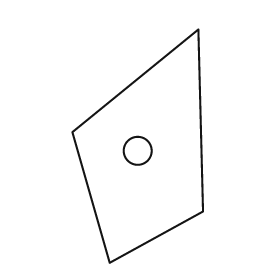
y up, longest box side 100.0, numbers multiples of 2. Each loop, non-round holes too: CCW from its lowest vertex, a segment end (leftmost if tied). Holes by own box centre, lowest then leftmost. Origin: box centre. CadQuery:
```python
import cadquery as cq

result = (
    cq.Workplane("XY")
    .moveTo(-12.0, -50.0)
    .lineTo(28.0, -28.0)
    .lineTo(26.0, 50.0)
    .lineTo(-28.0, 6.0)
    .close()
    .moveTo(0.0, -2.0)
    .circle(6.0)
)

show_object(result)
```